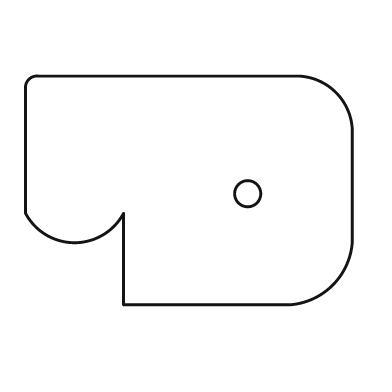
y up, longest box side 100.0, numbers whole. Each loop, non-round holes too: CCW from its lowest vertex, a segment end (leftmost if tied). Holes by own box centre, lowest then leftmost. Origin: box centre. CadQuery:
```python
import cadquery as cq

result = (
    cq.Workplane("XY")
    .moveTo(-20.0, -35.0)
    .lineTo(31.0, -35.0)
    .threePointArc((44.0, -29.0), (50.0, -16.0))
    .lineTo(50.0, 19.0)
    .threePointArc((45.0, 30.0), (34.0, 35.0))
    .lineTo(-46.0, 35.0)
    .threePointArc((-49.0, 34.0), (-50.0, 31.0))
    .lineTo(-50.0, -7.0)
    .threePointArc((-35.0, -16.0), (-20.0, -7.0))
    .close()
    .moveTo(18.0, -1.0)
    .circle(4.0)
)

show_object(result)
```